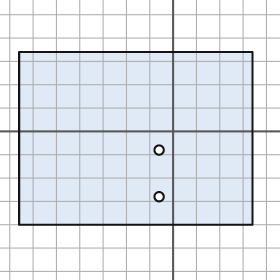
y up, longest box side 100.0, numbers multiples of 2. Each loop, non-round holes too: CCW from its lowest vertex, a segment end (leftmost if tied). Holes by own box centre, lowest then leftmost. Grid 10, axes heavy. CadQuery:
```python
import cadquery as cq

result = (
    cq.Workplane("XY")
    .moveTo(-66.0, -40.0)
    .lineTo(34.0, -40.0)
    .lineTo(34.0, 34.0)
    .lineTo(-66.0, 34.0)
    .close()
    .moveTo(-6.0, -28.0)
    .circle(2.0)
    .moveTo(-6.0, -8.0)
    .circle(2.0)
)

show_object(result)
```